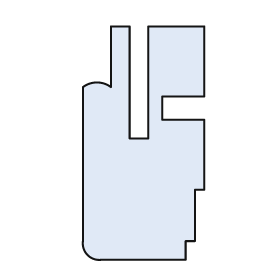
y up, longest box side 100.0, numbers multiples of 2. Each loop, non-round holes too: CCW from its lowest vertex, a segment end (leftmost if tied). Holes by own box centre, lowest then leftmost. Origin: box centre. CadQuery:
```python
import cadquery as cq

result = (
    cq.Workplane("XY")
    .moveTo(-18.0, -50.0)
    .lineTo(18.0, -50.0)
    .lineTo(18.0, -42.0)
    .lineTo(22.0, -42.0)
    .lineTo(22.0, -20.0)
    .lineTo(26.0, -20.0)
    .lineTo(26.0, 10.0)
    .lineTo(8.0, 10.0)
    .lineTo(8.0, 20.0)
    .lineTo(26.0, 20.0)
    .lineTo(26.0, 50.0)
    .lineTo(2.0, 50.0)
    .lineTo(2.0, 2.0)
    .lineTo(-6.0, 2.0)
    .lineTo(-6.0, 50.0)
    .lineTo(-14.0, 50.0)
    .lineTo(-14.0, 24.0)
    .threePointArc((-20.0, 26.0), (-26.0, 24.0))
    .lineTo(-26.0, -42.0)
    .threePointArc((-24.0, -48.0), (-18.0, -50.0))
    .close()
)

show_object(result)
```